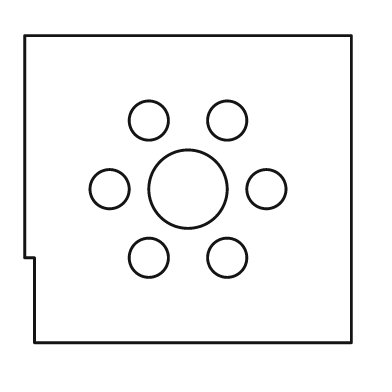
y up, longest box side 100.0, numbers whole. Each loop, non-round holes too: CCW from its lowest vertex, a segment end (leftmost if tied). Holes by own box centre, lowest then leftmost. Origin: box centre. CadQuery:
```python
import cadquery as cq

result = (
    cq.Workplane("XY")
    .moveTo(-47.0, -47.0)
    .lineTo(50.0, -47.0)
    .lineTo(50.0, 47.0)
    .lineTo(-50.0, 47.0)
    .lineTo(-50.0, -21.0)
    .lineTo(-47.0, -21.0)
    .close()
    .moveTo(-12.0, -21.0)
    .circle(6.0)
    .moveTo(12.0, -21.0)
    .circle(6.0)
    .moveTo(-24.0, 0.0)
    .circle(6.0)
    .moveTo(0.0, 0.0)
    .circle(12.0)
    .moveTo(24.0, 0.0)
    .circle(6.0)
    .moveTo(-12.0, 21.0)
    .circle(6.0)
    .moveTo(12.0, 21.0)
    .circle(6.0)
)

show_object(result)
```